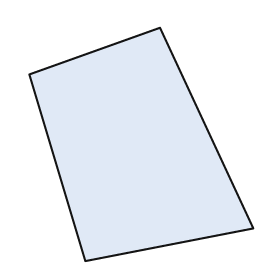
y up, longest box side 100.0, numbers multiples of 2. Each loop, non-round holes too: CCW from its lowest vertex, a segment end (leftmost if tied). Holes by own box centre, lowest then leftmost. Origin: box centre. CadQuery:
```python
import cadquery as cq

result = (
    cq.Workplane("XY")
    .moveTo(-24.0, -50.0)
    .lineTo(48.0, -36.0)
    .lineTo(8.0, 50.0)
    .lineTo(-48.0, 30.0)
    .close()
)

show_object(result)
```